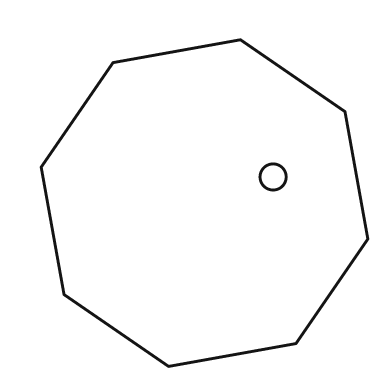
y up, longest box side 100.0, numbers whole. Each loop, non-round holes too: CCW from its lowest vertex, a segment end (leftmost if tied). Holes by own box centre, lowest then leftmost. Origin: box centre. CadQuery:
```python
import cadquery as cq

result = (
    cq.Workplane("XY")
    .moveTo(-11.0, -50.0)
    .lineTo(28.0, -43.0)
    .lineTo(50.0, -11.0)
    .lineTo(43.0, 28.0)
    .lineTo(11.0, 50.0)
    .lineTo(-28.0, 43.0)
    .lineTo(-50.0, 11.0)
    .lineTo(-43.0, -28.0)
    .close()
    .moveTo(21.0, 8.0)
    .circle(4.0)
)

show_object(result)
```